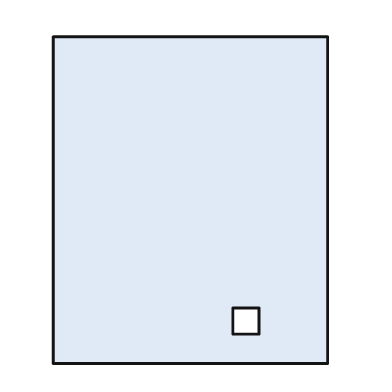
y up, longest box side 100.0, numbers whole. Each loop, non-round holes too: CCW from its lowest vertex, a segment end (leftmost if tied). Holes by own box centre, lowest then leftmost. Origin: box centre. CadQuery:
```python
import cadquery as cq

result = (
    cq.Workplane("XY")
    .moveTo(-42.0, -50.0)
    .lineTo(42.0, -50.0)
    .lineTo(42.0, 50.0)
    .lineTo(-42.0, 50.0)
    .close()
    .moveTo(13.0, -41.0)
    .lineTo(21.0, -41.0)
    .lineTo(21.0, -33.0)
    .lineTo(13.0, -33.0)
    .close()
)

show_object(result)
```